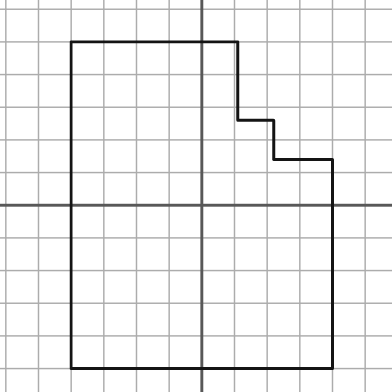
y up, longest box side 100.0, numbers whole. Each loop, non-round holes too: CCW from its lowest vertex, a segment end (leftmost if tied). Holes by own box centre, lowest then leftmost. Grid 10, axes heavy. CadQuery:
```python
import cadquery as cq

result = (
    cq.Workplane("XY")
    .moveTo(-40.0, -50.0)
    .lineTo(40.0, -50.0)
    .lineTo(40.0, 14.0)
    .lineTo(22.0, 14.0)
    .lineTo(22.0, 26.0)
    .lineTo(11.0, 26.0)
    .lineTo(11.0, 50.0)
    .lineTo(-40.0, 50.0)
    .close()
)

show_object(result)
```